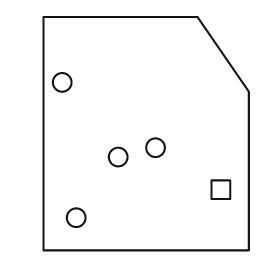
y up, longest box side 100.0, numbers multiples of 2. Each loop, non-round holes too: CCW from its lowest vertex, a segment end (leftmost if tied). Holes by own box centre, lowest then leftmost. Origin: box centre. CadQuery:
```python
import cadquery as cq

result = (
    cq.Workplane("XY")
    .moveTo(-44.0, -50.0)
    .lineTo(44.0, -50.0)
    .lineTo(44.0, 18.0)
    .lineTo(22.0, 50.0)
    .lineTo(-44.0, 50.0)
    .close()
    .moveTo(-30.0, -36.0)
    .circle(4.0)
    .moveTo(28.0, -28.0)
    .lineTo(36.0, -28.0)
    .lineTo(36.0, -20.0)
    .lineTo(28.0, -20.0)
    .close()
    .moveTo(-12.0, -10.0)
    .circle(4.0)
    .moveTo(4.0, -6.0)
    .circle(4.0)
    .moveTo(-36.0, 22.0)
    .circle(4.0)
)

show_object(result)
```